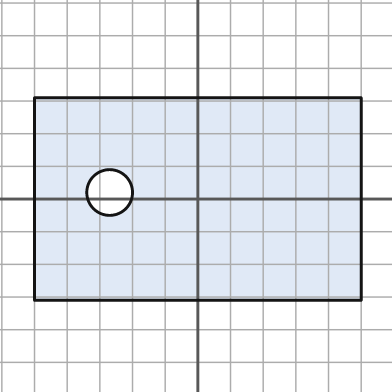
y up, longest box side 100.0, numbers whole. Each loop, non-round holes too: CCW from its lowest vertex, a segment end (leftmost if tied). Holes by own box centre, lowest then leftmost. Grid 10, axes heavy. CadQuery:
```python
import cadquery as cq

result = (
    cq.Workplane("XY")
    .moveTo(-50.0, -31.0)
    .lineTo(50.0, -31.0)
    .lineTo(50.0, 31.0)
    .lineTo(-50.0, 31.0)
    .close()
    .moveTo(-27.0, 2.0)
    .circle(7.0)
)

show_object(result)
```